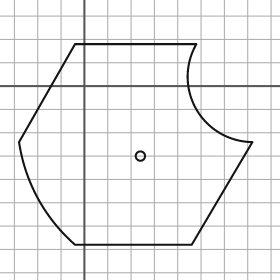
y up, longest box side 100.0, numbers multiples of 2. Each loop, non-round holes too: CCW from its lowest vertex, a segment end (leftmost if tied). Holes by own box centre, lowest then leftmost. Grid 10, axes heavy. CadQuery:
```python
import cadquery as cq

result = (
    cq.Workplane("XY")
    .moveTo(-4.0, -68.0)
    .lineTo(46.0, -68.0)
    .lineTo(72.0, -24.0)
    .threePointArc((48.0, -10.0), (48.0, 18.0))
    .lineTo(-4.0, 18.0)
    .lineTo(-28.0, -24.0)
    .threePointArc((-20.0, -48.0), (-4.0, -68.0))
    .close()
    .moveTo(24.0, -30.0)
    .circle(2.0)
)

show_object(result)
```